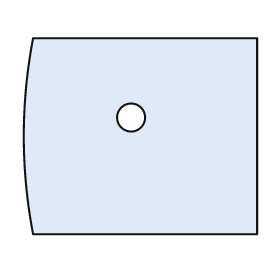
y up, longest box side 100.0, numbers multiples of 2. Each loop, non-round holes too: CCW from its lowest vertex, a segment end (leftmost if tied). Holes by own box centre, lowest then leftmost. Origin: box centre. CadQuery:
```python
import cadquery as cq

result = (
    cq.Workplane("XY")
    .moveTo(-46.0, -42.0)
    .lineTo(50.0, -42.0)
    .lineTo(50.0, 42.0)
    .lineTo(-46.0, 42.0)
    .threePointArc((-50.0, 0.0), (-46.0, -42.0))
    .close()
    .moveTo(-4.0, 8.0)
    .circle(6.0)
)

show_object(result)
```